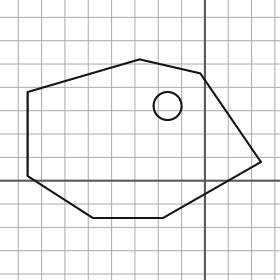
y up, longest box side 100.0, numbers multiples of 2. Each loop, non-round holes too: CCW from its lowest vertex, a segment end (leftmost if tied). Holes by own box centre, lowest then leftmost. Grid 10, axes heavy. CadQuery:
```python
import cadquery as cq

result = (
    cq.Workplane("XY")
    .moveTo(-48.0, -16.0)
    .lineTo(-18.0, -16.0)
    .lineTo(24.0, 8.0)
    .lineTo(-2.0, 46.0)
    .lineTo(-28.0, 52.0)
    .lineTo(-76.0, 38.0)
    .lineTo(-76.0, 2.0)
    .close()
    .moveTo(-16.0, 32.0)
    .circle(6.0)
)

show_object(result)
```